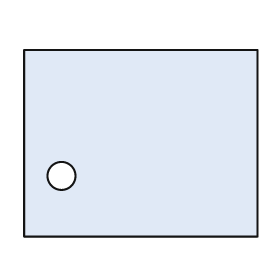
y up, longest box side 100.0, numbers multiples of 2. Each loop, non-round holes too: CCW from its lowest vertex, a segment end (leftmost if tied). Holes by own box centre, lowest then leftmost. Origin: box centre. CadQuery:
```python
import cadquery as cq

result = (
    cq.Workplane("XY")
    .moveTo(-50.0, -40.0)
    .lineTo(50.0, -40.0)
    .lineTo(50.0, 40.0)
    .lineTo(-50.0, 40.0)
    .close()
    .moveTo(-34.0, -14.0)
    .circle(6.0)
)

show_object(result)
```